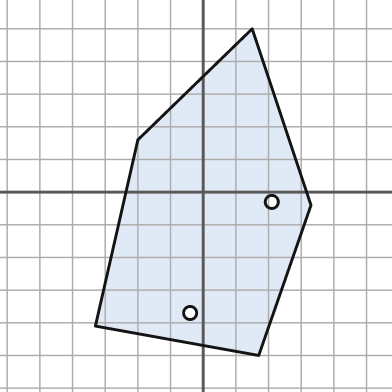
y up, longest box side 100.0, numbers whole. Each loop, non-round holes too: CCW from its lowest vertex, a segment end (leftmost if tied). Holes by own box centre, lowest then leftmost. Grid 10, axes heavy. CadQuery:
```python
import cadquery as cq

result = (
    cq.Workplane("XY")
    .moveTo(17.0, -50.0)
    .lineTo(33.0, -4.0)
    .lineTo(15.0, 50.0)
    .lineTo(-20.0, 16.0)
    .lineTo(-33.0, -41.0)
    .close()
    .moveTo(-4.0, -37.0)
    .circle(2.0)
    .moveTo(21.0, -3.0)
    .circle(2.0)
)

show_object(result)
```